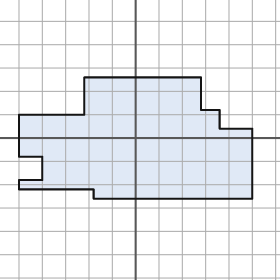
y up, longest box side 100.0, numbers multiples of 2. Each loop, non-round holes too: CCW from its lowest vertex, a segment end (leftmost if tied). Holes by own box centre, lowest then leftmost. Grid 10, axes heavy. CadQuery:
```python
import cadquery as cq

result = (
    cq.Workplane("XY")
    .moveTo(-18.0, -26.0)
    .lineTo(50.0, -26.0)
    .lineTo(50.0, 4.0)
    .lineTo(36.0, 4.0)
    .lineTo(36.0, 12.0)
    .lineTo(28.0, 12.0)
    .lineTo(28.0, 26.0)
    .lineTo(-22.0, 26.0)
    .lineTo(-22.0, 10.0)
    .lineTo(-50.0, 10.0)
    .lineTo(-50.0, -8.0)
    .lineTo(-40.0, -8.0)
    .lineTo(-40.0, -18.0)
    .lineTo(-50.0, -18.0)
    .lineTo(-50.0, -22.0)
    .lineTo(-18.0, -22.0)
    .close()
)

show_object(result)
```